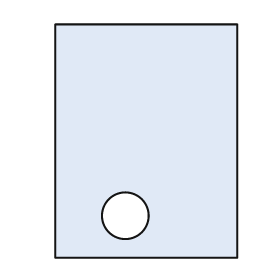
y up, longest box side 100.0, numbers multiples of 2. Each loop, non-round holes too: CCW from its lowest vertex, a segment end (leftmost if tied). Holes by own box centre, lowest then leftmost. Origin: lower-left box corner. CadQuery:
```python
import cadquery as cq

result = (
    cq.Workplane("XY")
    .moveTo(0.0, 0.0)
    .lineTo(78.0, 0.0)
    .lineTo(78.0, 100.0)
    .lineTo(0.0, 100.0)
    .close()
    .moveTo(30.0, 18.0)
    .circle(10.0)
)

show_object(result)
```